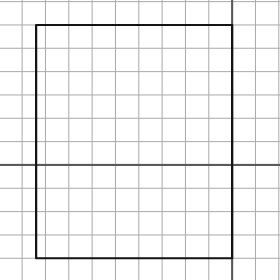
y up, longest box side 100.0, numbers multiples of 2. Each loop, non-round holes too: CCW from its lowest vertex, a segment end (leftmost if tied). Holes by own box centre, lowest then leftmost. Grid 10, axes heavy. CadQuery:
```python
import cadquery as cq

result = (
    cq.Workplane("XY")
    .moveTo(-84.0, -40.0)
    .lineTo(0.0, -40.0)
    .lineTo(0.0, 60.0)
    .lineTo(-84.0, 60.0)
    .close()
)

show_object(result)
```